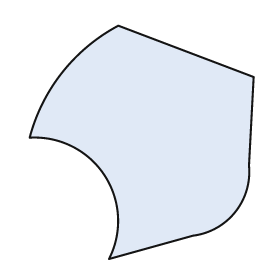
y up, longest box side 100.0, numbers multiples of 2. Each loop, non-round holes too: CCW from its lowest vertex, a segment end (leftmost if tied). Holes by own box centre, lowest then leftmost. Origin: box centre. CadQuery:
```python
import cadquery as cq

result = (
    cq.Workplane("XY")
    .moveTo(-14.0, -50.0)
    .lineTo(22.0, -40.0)
    .threePointArc((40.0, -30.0), (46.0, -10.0))
    .lineTo(48.0, 28.0)
    .lineTo(-10.0, 50.0)
    .threePointArc((-34.0, 30.0), (-48.0, 2.0))
    .threePointArc((-16.0, -14.0), (-14.0, -50.0))
    .close()
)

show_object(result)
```